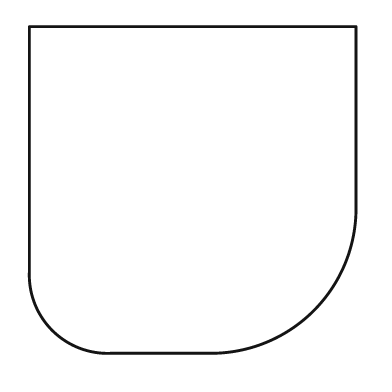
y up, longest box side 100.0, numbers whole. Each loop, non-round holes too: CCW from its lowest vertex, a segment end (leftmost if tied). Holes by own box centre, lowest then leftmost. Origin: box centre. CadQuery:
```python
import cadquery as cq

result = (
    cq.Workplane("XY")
    .moveTo(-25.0, -50.0)
    .lineTo(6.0, -50.0)
    .threePointArc((37.0, -37.0), (50.0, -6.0))
    .lineTo(50.0, 50.0)
    .lineTo(-50.0, 50.0)
    .lineTo(-50.0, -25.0)
    .threePointArc((-43.0, -43.0), (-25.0, -50.0))
    .close()
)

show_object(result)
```